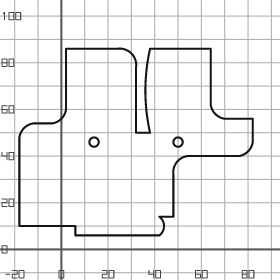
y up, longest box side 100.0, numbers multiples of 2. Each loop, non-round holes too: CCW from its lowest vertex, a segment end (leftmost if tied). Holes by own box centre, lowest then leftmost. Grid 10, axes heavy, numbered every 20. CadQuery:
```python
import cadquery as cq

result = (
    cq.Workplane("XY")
    .moveTo(6.0, 6.0)
    .lineTo(42.0, 6.0)
    .threePointArc((44.0, 10.0), (42.0, 14.0))
    .lineTo(48.0, 14.0)
    .lineTo(48.0, 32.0)
    .threePointArc((50.0, 38.0), (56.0, 40.0))
    .lineTo(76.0, 40.0)
    .threePointArc((80.0, 42.0), (82.0, 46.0))
    .lineTo(82.0, 56.0)
    .lineTo(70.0, 56.0)
    .threePointArc((66.0, 58.0), (64.0, 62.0))
    .lineTo(64.0, 86.0)
    .lineTo(38.0, 86.0)
    .threePointArc((36.0, 68.0), (38.0, 50.0))
    .lineTo(32.0, 50.0)
    .lineTo(32.0, 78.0)
    .threePointArc((30.0, 84.0), (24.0, 86.0))
    .lineTo(2.0, 86.0)
    .lineTo(2.0, 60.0)
    .threePointArc((0.0, 56.0), (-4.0, 54.0))
    .lineTo(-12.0, 54.0)
    .threePointArc((-16.0, 52.0), (-18.0, 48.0))
    .lineTo(-18.0, 10.0)
    .lineTo(6.0, 10.0)
    .close()
    .moveTo(14.0, 46.0)
    .circle(2.0)
    .moveTo(50.0, 46.0)
    .circle(2.0)
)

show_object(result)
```